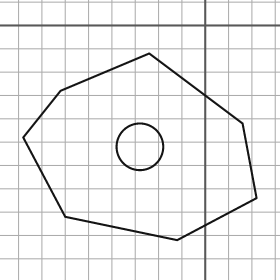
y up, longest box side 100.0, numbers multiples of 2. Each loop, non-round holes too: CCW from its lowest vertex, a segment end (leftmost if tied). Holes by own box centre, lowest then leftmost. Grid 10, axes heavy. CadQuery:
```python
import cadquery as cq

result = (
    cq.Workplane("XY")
    .moveTo(-12.0, -92.0)
    .lineTo(22.0, -74.0)
    .lineTo(16.0, -42.0)
    .lineTo(-24.0, -12.0)
    .lineTo(-62.0, -28.0)
    .lineTo(-78.0, -48.0)
    .lineTo(-60.0, -82.0)
    .close()
    .moveTo(-28.0, -52.0)
    .circle(10.0)
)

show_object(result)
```